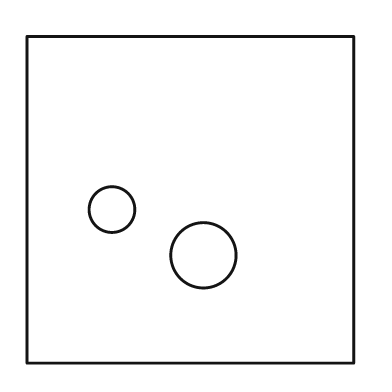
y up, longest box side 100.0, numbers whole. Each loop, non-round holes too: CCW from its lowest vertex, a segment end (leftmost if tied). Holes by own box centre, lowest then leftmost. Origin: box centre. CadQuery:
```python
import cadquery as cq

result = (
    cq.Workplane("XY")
    .moveTo(-50.0, -50.0)
    .lineTo(50.0, -50.0)
    .lineTo(50.0, 50.0)
    .lineTo(-50.0, 50.0)
    .close()
    .moveTo(4.0, -17.0)
    .circle(10.0)
    .moveTo(-24.0, -3.0)
    .circle(7.0)
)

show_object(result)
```